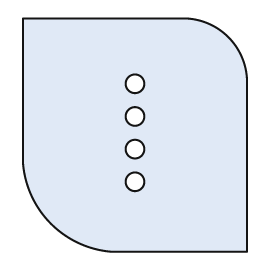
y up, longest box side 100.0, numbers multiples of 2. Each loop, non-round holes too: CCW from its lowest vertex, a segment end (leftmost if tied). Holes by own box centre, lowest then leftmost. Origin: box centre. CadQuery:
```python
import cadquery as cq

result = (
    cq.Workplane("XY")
    .moveTo(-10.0, -50.0)
    .lineTo(48.0, -50.0)
    .lineTo(48.0, 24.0)
    .threePointArc((40.0, 42.0), (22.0, 50.0))
    .lineTo(-48.0, 50.0)
    .lineTo(-48.0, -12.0)
    .threePointArc((-36.0, -38.0), (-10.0, -50.0))
    .close()
    .moveTo(0.0, -20.0)
    .circle(4.0)
    .moveTo(0.0, -6.0)
    .circle(4.0)
    .moveTo(0.0, 8.0)
    .circle(4.0)
    .moveTo(0.0, 22.0)
    .circle(4.0)
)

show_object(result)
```